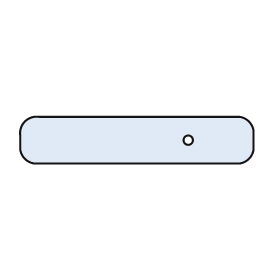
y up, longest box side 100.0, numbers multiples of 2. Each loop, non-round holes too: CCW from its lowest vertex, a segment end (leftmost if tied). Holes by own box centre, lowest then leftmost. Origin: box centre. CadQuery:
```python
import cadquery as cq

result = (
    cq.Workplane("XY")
    .moveTo(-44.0, -10.0)
    .lineTo(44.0, -10.0)
    .threePointArc((48.0, -8.0), (50.0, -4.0))
    .lineTo(50.0, 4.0)
    .threePointArc((48.0, 8.0), (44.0, 10.0))
    .lineTo(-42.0, 10.0)
    .threePointArc((-48.0, 8.0), (-50.0, 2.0))
    .lineTo(-50.0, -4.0)
    .threePointArc((-48.0, -8.0), (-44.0, -10.0))
    .close()
    .moveTo(22.0, 0.0)
    .circle(2.0)
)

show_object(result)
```